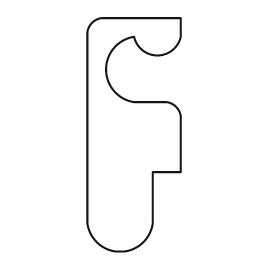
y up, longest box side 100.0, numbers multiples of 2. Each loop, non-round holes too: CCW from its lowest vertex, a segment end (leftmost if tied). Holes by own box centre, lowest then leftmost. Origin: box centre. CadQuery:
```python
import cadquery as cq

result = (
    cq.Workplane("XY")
    .moveTo(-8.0, -50.0)
    .lineTo(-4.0, -50.0)
    .threePointArc((4.0, -46.0), (8.0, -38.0))
    .lineTo(8.0, -16.0)
    .lineTo(20.0, -16.0)
    .lineTo(20.0, 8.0)
    .threePointArc((18.0, 12.0), (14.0, 14.0))
    .lineTo(0.0, 14.0)
    .threePointArc((-12.0, 28.0), (0.0, 42.0))
    .threePointArc((10.0, 34.0), (20.0, 42.0))
    .lineTo(20.0, 50.0)
    .lineTo(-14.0, 50.0)
    .threePointArc((-18.0, 48.0), (-20.0, 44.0))
    .lineTo(-20.0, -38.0)
    .threePointArc((-16.0, -46.0), (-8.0, -50.0))
    .close()
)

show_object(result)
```